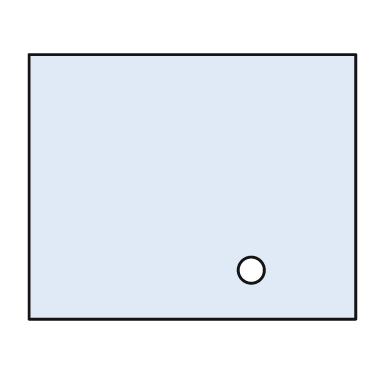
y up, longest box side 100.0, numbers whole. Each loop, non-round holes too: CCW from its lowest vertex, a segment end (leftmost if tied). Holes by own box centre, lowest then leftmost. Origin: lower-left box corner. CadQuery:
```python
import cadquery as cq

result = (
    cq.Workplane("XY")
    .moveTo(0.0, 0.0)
    .lineTo(100.0, 0.0)
    .lineTo(100.0, 81.0)
    .lineTo(0.0, 81.0)
    .close()
    .moveTo(68.0, 15.0)
    .circle(4.0)
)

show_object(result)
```